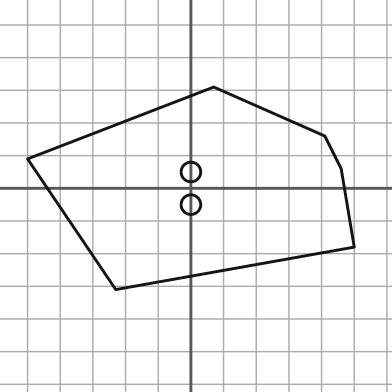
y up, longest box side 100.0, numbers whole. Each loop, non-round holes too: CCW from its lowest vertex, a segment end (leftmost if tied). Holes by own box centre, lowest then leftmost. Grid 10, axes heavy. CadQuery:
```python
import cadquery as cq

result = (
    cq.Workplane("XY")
    .moveTo(-23.0, -31.0)
    .lineTo(50.0, -18.0)
    .lineTo(46.0, 6.0)
    .lineTo(41.0, 16.0)
    .lineTo(7.0, 31.0)
    .lineTo(-50.0, 9.0)
    .close()
    .moveTo(0.0, -5.0)
    .circle(3.0)
    .moveTo(0.0, 5.0)
    .circle(3.0)
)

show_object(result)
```